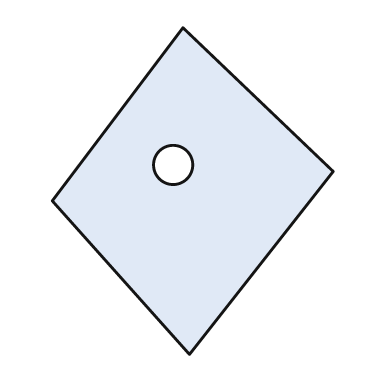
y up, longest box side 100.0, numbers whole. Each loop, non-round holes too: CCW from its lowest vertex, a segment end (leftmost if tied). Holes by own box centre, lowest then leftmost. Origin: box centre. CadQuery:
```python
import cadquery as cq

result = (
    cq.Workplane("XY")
    .moveTo(-1.0, -50.0)
    .lineTo(43.0, 6.0)
    .lineTo(-3.0, 50.0)
    .lineTo(-43.0, -3.0)
    .close()
    .moveTo(-6.0, 8.0)
    .circle(6.0)
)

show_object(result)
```